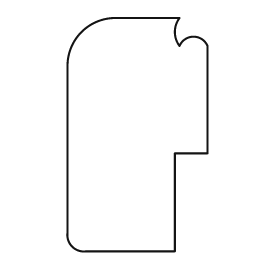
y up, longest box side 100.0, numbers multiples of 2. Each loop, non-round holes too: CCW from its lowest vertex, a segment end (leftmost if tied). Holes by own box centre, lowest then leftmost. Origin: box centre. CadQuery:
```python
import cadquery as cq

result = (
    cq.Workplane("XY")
    .moveTo(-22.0, -50.0)
    .lineTo(16.0, -50.0)
    .lineTo(16.0, -8.0)
    .lineTo(30.0, -8.0)
    .lineTo(30.0, 38.0)
    .threePointArc((24.0, 42.0), (18.0, 38.0))
    .threePointArc((16.0, 44.0), (18.0, 50.0))
    .lineTo(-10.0, 50.0)
    .threePointArc((-24.0, 44.0), (-30.0, 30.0))
    .lineTo(-30.0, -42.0)
    .threePointArc((-28.0, -48.0), (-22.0, -50.0))
    .close()
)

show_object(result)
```